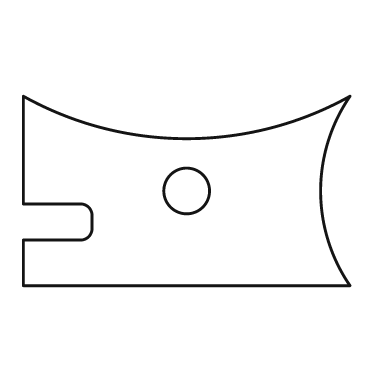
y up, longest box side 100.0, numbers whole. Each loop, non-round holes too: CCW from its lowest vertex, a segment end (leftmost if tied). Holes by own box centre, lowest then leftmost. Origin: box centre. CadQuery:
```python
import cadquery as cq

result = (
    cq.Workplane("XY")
    .moveTo(-50.0, -29.0)
    .lineTo(50.0, -29.0)
    .threePointArc((41.0, 0.0), (50.0, 29.0))
    .threePointArc((0.0, 16.0), (-50.0, 29.0))
    .lineTo(-50.0, -4.0)
    .lineTo(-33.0, -4.0)
    .threePointArc((-30.0, -5.0), (-29.0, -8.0))
    .lineTo(-29.0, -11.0)
    .threePointArc((-30.0, -14.0), (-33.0, -15.0))
    .lineTo(-50.0, -15.0)
    .close()
    .moveTo(0.0, 0.0)
    .circle(7.0)
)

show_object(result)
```